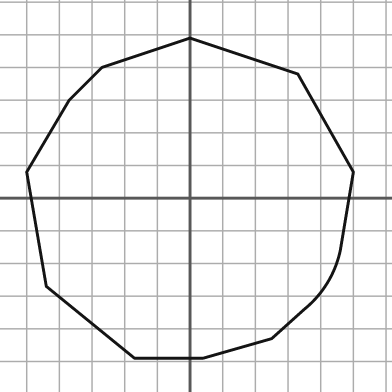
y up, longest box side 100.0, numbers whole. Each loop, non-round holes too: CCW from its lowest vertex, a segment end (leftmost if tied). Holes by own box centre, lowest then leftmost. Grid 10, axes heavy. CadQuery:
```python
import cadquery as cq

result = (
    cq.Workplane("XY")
    .moveTo(-17.0, -49.0)
    .lineTo(4.0, -49.0)
    .lineTo(25.0, -43.0)
    .lineTo(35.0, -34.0)
    .threePointArc((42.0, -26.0), (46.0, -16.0))
    .lineTo(50.0, 8.0)
    .lineTo(33.0, 38.0)
    .lineTo(0.0, 49.0)
    .lineTo(-27.0, 40.0)
    .lineTo(-37.0, 30.0)
    .lineTo(-50.0, 8.0)
    .lineTo(-44.0, -27.0)
    .close()
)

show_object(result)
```